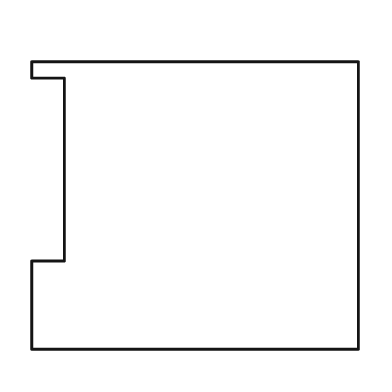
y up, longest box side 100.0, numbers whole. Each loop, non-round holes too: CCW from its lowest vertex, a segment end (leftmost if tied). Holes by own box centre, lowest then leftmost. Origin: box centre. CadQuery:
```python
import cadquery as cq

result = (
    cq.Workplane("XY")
    .moveTo(-50.0, -44.0)
    .lineTo(50.0, -44.0)
    .lineTo(50.0, 44.0)
    .lineTo(-50.0, 44.0)
    .lineTo(-50.0, 39.0)
    .lineTo(-40.0, 39.0)
    .lineTo(-40.0, -17.0)
    .lineTo(-50.0, -17.0)
    .close()
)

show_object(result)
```